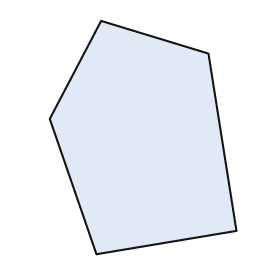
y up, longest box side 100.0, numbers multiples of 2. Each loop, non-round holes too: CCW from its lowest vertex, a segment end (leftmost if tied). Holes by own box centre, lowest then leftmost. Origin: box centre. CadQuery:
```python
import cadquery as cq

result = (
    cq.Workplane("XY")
    .moveTo(-20.0, -50.0)
    .lineTo(40.0, -40.0)
    .lineTo(28.0, 36.0)
    .lineTo(-18.0, 50.0)
    .lineTo(-40.0, 8.0)
    .close()
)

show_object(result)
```